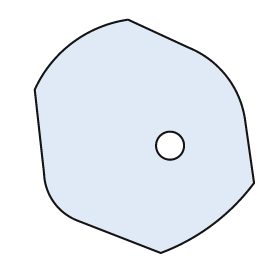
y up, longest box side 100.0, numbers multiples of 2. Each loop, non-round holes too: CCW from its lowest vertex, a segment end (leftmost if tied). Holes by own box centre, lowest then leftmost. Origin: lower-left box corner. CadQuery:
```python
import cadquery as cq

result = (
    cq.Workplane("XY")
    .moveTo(54.0, 0.0)
    .threePointArc((76.0, 12.0), (94.0, 30.0))
    .lineTo(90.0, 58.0)
    .threePointArc((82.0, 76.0), (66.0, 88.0))
    .lineTo(40.0, 100.0)
    .threePointArc((16.0, 90.0), (0.0, 70.0))
    .lineTo(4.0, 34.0)
    .threePointArc((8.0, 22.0), (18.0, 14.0))
    .close()
    .moveTo(58.0, 46.0)
    .circle(6.0)
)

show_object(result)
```